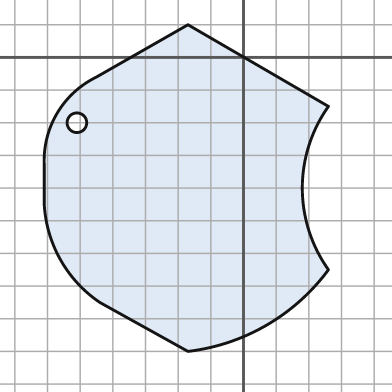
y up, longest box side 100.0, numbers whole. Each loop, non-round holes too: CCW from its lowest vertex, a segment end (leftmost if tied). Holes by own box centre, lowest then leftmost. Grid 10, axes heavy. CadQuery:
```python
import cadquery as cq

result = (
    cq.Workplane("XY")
    .moveTo(-17.0, -90.0)
    .threePointArc((7.0, -82.0), (26.0, -65.0))
    .threePointArc((18.0, -40.0), (26.0, -15.0))
    .lineTo(-17.0, 10.0)
    .lineTo(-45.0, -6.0)
    .threePointArc((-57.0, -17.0), (-61.0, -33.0))
    .lineTo(-61.0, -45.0)
    .threePointArc((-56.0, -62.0), (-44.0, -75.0))
    .close()
    .moveTo(-51.0, -20.0)
    .circle(3.0)
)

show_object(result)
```